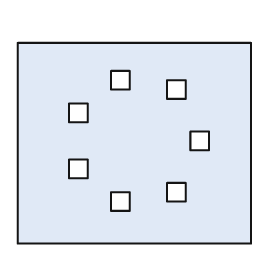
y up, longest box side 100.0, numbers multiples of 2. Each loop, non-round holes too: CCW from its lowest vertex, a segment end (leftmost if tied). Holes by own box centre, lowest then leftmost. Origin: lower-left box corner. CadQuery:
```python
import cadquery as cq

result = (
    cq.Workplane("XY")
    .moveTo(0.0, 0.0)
    .lineTo(100.0, 0.0)
    .lineTo(100.0, 86.0)
    .lineTo(0.0, 86.0)
    .close()
    .moveTo(40.0, 14.0)
    .lineTo(48.0, 14.0)
    .lineTo(48.0, 22.0)
    .lineTo(40.0, 22.0)
    .close()
    .moveTo(64.0, 18.0)
    .lineTo(72.0, 18.0)
    .lineTo(72.0, 26.0)
    .lineTo(64.0, 26.0)
    .close()
    .moveTo(22.0, 28.0)
    .lineTo(30.0, 28.0)
    .lineTo(30.0, 36.0)
    .lineTo(22.0, 36.0)
    .close()
    .moveTo(74.0, 40.0)
    .lineTo(82.0, 40.0)
    .lineTo(82.0, 48.0)
    .lineTo(74.0, 48.0)
    .close()
    .moveTo(22.0, 52.0)
    .lineTo(30.0, 52.0)
    .lineTo(30.0, 60.0)
    .lineTo(22.0, 60.0)
    .close()
    .moveTo(64.0, 62.0)
    .lineTo(72.0, 62.0)
    .lineTo(72.0, 70.0)
    .lineTo(64.0, 70.0)
    .close()
    .moveTo(40.0, 66.0)
    .lineTo(48.0, 66.0)
    .lineTo(48.0, 74.0)
    .lineTo(40.0, 74.0)
    .close()
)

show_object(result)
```